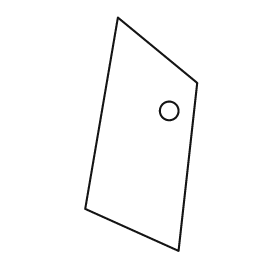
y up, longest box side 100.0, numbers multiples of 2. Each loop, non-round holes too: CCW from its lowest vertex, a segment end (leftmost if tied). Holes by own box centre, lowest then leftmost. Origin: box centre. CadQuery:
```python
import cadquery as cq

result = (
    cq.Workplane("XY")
    .moveTo(16.0, -50.0)
    .lineTo(24.0, 22.0)
    .lineTo(-10.0, 50.0)
    .lineTo(-24.0, -32.0)
    .close()
    .moveTo(12.0, 10.0)
    .circle(4.0)
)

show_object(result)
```